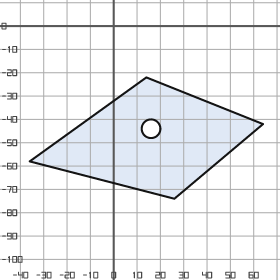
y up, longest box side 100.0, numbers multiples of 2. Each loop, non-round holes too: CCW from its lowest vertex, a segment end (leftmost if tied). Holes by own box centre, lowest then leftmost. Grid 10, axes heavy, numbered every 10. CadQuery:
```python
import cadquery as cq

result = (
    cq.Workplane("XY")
    .moveTo(26.0, -74.0)
    .lineTo(64.0, -42.0)
    .lineTo(14.0, -22.0)
    .lineTo(-36.0, -58.0)
    .close()
    .moveTo(16.0, -44.0)
    .circle(4.0)
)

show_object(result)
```